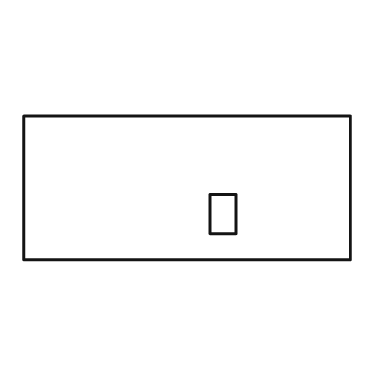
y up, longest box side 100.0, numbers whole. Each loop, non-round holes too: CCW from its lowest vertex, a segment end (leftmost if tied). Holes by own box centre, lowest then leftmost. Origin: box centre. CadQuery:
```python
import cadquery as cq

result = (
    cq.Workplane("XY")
    .moveTo(-50.0, -22.0)
    .lineTo(50.0, -22.0)
    .lineTo(50.0, 22.0)
    .lineTo(-50.0, 22.0)
    .close()
    .moveTo(7.0, -14.0)
    .lineTo(15.0, -14.0)
    .lineTo(15.0, -2.0)
    .lineTo(7.0, -2.0)
    .close()
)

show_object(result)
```